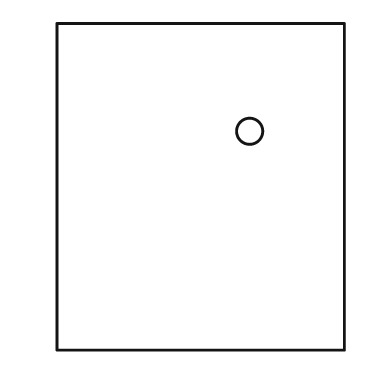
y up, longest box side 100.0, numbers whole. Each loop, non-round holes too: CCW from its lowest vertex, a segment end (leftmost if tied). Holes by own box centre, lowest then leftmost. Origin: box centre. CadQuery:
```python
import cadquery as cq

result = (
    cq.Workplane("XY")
    .moveTo(-44.0, -50.0)
    .lineTo(44.0, -50.0)
    .lineTo(44.0, 50.0)
    .lineTo(-44.0, 50.0)
    .close()
    .moveTo(15.0, 17.0)
    .circle(4.0)
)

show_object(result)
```